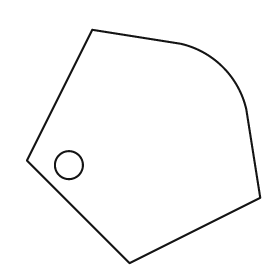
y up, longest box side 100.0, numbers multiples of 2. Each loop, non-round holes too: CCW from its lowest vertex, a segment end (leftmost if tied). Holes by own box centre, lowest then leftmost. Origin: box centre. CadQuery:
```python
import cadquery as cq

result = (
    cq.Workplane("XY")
    .moveTo(-6.0, -50.0)
    .lineTo(50.0, -22.0)
    .lineTo(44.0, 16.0)
    .threePointArc((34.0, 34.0), (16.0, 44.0))
    .lineTo(-22.0, 50.0)
    .lineTo(-50.0, -6.0)
    .close()
    .moveTo(-32.0, -8.0)
    .circle(6.0)
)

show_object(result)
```